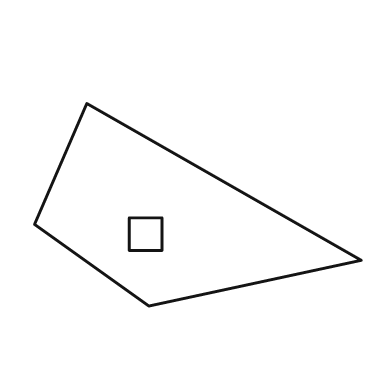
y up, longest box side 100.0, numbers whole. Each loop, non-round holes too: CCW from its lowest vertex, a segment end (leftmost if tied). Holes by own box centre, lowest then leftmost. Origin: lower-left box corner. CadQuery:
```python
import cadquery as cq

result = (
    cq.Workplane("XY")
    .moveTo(35.0, 0.0)
    .lineTo(100.0, 14.0)
    .lineTo(16.0, 62.0)
    .lineTo(0.0, 25.0)
    .close()
    .moveTo(29.0, 17.0)
    .lineTo(39.0, 17.0)
    .lineTo(39.0, 27.0)
    .lineTo(29.0, 27.0)
    .close()
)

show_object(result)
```